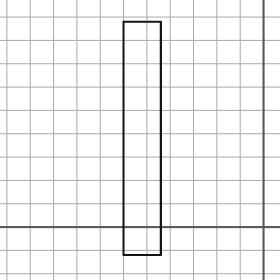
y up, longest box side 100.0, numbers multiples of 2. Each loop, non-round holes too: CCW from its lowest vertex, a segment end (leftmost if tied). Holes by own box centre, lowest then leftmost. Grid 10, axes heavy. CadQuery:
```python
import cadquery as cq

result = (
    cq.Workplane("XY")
    .moveTo(-60.0, -12.0)
    .lineTo(-44.0, -12.0)
    .lineTo(-44.0, 88.0)
    .lineTo(-60.0, 88.0)
    .close()
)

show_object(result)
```